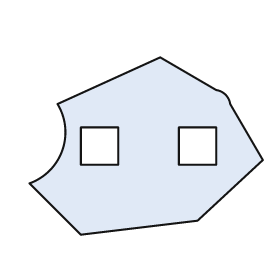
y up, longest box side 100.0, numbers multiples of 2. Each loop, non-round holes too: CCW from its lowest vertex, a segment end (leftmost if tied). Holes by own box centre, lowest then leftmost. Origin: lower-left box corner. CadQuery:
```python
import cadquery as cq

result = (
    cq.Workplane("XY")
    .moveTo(22.0, 0.0)
    .lineTo(72.0, 6.0)
    .lineTo(100.0, 32.0)
    .lineTo(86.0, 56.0)
    .threePointArc((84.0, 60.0), (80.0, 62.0))
    .lineTo(56.0, 76.0)
    .lineTo(12.0, 56.0)
    .threePointArc((14.0, 36.0), (0.0, 22.0))
    .close()
    .moveTo(22.0, 30.0)
    .lineTo(38.0, 30.0)
    .lineTo(38.0, 46.0)
    .lineTo(22.0, 46.0)
    .close()
    .moveTo(64.0, 30.0)
    .lineTo(80.0, 30.0)
    .lineTo(80.0, 46.0)
    .lineTo(64.0, 46.0)
    .close()
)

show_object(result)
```